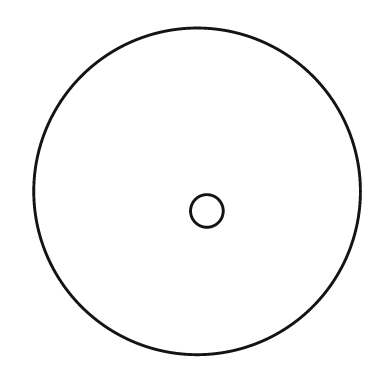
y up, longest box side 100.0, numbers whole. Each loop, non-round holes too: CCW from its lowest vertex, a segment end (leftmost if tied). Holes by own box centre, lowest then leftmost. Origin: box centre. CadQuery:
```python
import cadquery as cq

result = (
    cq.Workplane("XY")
    .moveTo(0.0, 0.0)
    .circle(50.0)
    .moveTo(3.0, -6.0)
    .circle(5.0)
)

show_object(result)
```